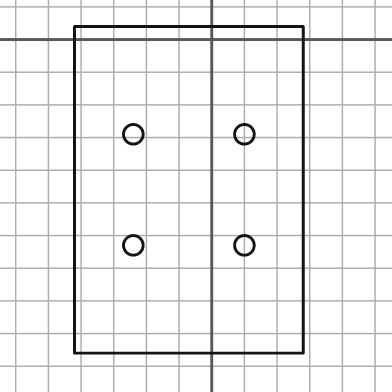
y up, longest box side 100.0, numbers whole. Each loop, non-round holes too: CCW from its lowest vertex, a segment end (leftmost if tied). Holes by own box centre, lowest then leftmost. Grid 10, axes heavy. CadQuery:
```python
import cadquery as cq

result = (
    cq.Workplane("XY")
    .moveTo(-42.0, -96.0)
    .lineTo(28.0, -96.0)
    .lineTo(28.0, 4.0)
    .lineTo(-42.0, 4.0)
    .close()
    .moveTo(-24.0, -63.0)
    .circle(3.0)
    .moveTo(10.0, -63.0)
    .circle(3.0)
    .moveTo(-24.0, -29.0)
    .circle(3.0)
    .moveTo(10.0, -29.0)
    .circle(3.0)
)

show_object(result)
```